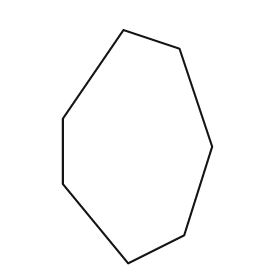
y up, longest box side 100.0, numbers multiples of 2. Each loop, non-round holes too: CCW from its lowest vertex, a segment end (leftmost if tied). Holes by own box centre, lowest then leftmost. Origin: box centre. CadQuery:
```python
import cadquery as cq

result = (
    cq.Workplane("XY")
    .moveTo(-4.0, -50.0)
    .lineTo(20.0, -38.0)
    .lineTo(32.0, 0.0)
    .lineTo(18.0, 42.0)
    .lineTo(-6.0, 50.0)
    .lineTo(-32.0, 12.0)
    .lineTo(-32.0, -16.0)
    .close()
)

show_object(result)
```